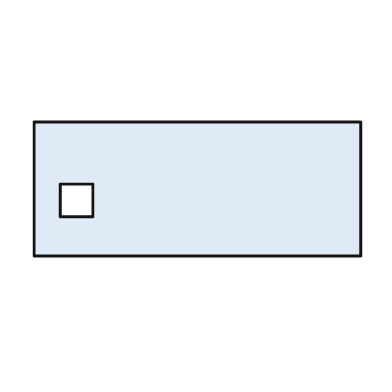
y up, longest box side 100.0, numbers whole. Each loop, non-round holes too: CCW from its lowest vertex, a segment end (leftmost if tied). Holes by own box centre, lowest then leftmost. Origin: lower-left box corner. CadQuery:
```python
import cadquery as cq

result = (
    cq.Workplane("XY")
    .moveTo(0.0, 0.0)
    .lineTo(100.0, 0.0)
    .lineTo(100.0, 41.0)
    .lineTo(0.0, 41.0)
    .close()
    .moveTo(8.0, 12.0)
    .lineTo(18.0, 12.0)
    .lineTo(18.0, 22.0)
    .lineTo(8.0, 22.0)
    .close()
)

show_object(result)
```